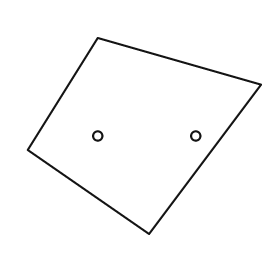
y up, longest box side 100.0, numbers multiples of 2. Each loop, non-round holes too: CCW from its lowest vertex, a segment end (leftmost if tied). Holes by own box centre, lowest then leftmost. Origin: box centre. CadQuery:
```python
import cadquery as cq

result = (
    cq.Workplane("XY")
    .moveTo(2.0, -42.0)
    .lineTo(50.0, 22.0)
    .lineTo(-20.0, 42.0)
    .lineTo(-50.0, -6.0)
    .close()
    .moveTo(-20.0, 0.0)
    .circle(2.0)
    .moveTo(22.0, 0.0)
    .circle(2.0)
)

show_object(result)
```